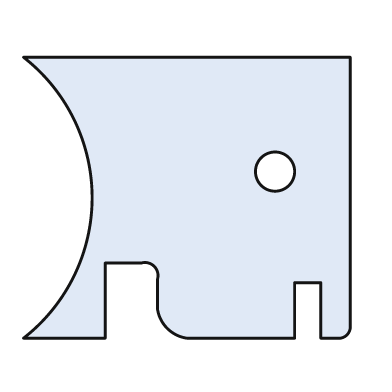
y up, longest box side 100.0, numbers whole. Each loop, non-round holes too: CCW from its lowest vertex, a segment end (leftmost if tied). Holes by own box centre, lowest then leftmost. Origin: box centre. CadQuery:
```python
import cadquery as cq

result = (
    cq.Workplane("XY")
    .moveTo(-50.0, -43.0)
    .lineTo(-25.0, -43.0)
    .lineTo(-25.0, -20.0)
    .lineTo(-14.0, -20.0)
    .threePointArc((-10.0, -21.0), (-9.0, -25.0))
    .lineTo(-9.0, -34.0)
    .threePointArc((-6.0, -40.0), (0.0, -43.0))
    .lineTo(33.0, -43.0)
    .lineTo(33.0, -26.0)
    .lineTo(41.0, -26.0)
    .lineTo(41.0, -43.0)
    .lineTo(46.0, -43.0)
    .threePointArc((49.0, -42.0), (50.0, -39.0))
    .lineTo(50.0, 43.0)
    .lineTo(-50.0, 43.0)
    .threePointArc((-29.0, 0.0), (-50.0, -43.0))
    .close()
    .moveTo(27.0, 8.0)
    .circle(6.0)
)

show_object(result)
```